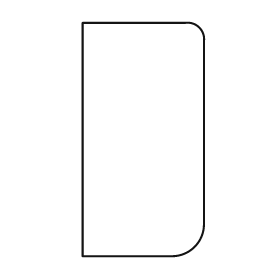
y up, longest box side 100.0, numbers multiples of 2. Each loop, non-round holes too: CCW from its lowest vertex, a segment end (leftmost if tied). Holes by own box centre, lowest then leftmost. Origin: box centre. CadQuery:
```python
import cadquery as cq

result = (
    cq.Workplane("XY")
    .moveTo(-26.0, -50.0)
    .lineTo(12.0, -50.0)
    .threePointArc((22.0, -46.0), (26.0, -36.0))
    .lineTo(26.0, 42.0)
    .threePointArc((24.0, 48.0), (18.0, 50.0))
    .lineTo(-26.0, 50.0)
    .close()
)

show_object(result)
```